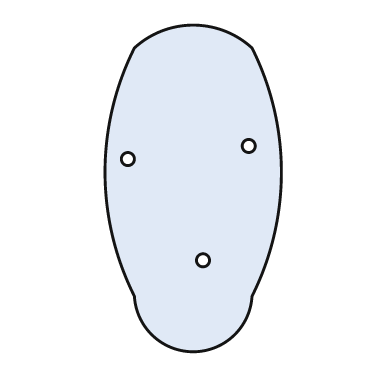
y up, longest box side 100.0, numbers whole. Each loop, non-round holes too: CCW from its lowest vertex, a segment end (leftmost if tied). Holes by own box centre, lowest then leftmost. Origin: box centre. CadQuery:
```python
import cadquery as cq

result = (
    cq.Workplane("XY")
    .moveTo(-18.0, -33.0)
    .threePointArc((0.0, -50.0), (18.0, -33.0))
    .threePointArc((27.0, 5.0), (18.0, 43.0))
    .threePointArc((0.0, 50.0), (-18.0, 43.0))
    .threePointArc((-27.0, 5.0), (-18.0, -33.0))
    .close()
    .moveTo(3.0, -22.0)
    .circle(2.0)
    .moveTo(-20.0, 9.0)
    .circle(2.0)
    .moveTo(17.0, 13.0)
    .circle(2.0)
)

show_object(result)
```